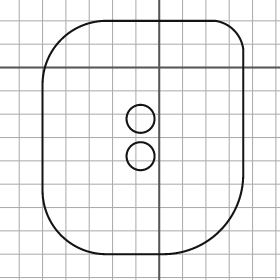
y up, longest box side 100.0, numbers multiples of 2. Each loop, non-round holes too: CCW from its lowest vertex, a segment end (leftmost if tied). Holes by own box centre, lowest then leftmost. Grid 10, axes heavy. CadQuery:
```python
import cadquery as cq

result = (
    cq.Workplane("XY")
    .moveTo(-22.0, -80.0)
    .lineTo(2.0, -80.0)
    .threePointArc((26.0, -70.0), (36.0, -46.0))
    .lineTo(36.0, 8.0)
    .threePointArc((32.0, 16.0), (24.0, 20.0))
    .lineTo(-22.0, 20.0)
    .threePointArc((-42.0, 12.0), (-50.0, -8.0))
    .lineTo(-50.0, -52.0)
    .threePointArc((-42.0, -72.0), (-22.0, -80.0))
    .close()
    .moveTo(-8.0, -38.0)
    .circle(6.0)
    .moveTo(-8.0, -22.0)
    .circle(6.0)
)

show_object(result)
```